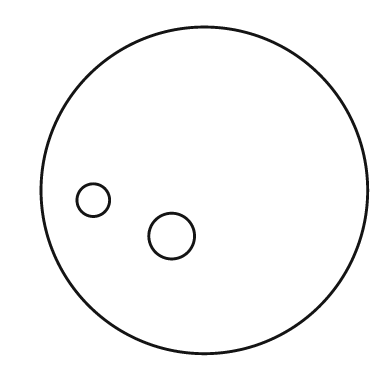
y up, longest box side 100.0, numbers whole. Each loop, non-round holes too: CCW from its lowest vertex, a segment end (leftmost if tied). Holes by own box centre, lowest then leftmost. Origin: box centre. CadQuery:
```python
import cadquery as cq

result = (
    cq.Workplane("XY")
    .moveTo(0.0, 0.0)
    .circle(50.0)
    .moveTo(-10.0, -14.0)
    .circle(7.0)
    .moveTo(-34.0, -3.0)
    .circle(5.0)
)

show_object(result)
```